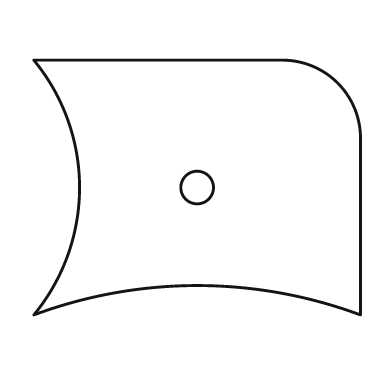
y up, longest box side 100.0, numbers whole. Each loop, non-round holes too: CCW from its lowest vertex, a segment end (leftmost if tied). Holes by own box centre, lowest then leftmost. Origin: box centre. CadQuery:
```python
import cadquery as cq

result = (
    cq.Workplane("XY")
    .moveTo(-50.0, -39.0)
    .threePointArc((0.0, -30.0), (50.0, -39.0))
    .lineTo(50.0, 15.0)
    .threePointArc((43.0, 32.0), (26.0, 39.0))
    .lineTo(-50.0, 39.0)
    .threePointArc((-36.0, 0.0), (-50.0, -39.0))
    .close()
    .moveTo(0.0, 0.0)
    .circle(5.0)
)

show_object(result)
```